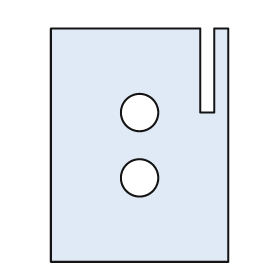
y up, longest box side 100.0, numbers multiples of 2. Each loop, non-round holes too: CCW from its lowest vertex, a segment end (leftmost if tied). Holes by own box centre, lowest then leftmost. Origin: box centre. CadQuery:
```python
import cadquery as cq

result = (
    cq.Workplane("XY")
    .moveTo(-38.0, -50.0)
    .lineTo(38.0, -50.0)
    .lineTo(38.0, 50.0)
    .lineTo(32.0, 50.0)
    .lineTo(32.0, 14.0)
    .lineTo(26.0, 14.0)
    .lineTo(26.0, 50.0)
    .lineTo(-38.0, 50.0)
    .close()
    .moveTo(0.0, -14.0)
    .circle(8.0)
    .moveTo(0.0, 14.0)
    .circle(8.0)
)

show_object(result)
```